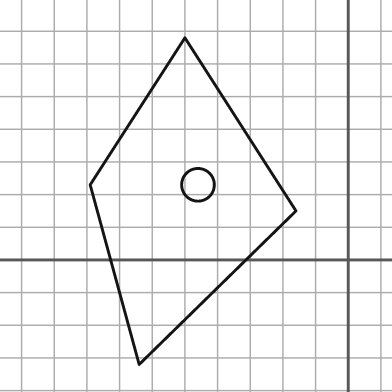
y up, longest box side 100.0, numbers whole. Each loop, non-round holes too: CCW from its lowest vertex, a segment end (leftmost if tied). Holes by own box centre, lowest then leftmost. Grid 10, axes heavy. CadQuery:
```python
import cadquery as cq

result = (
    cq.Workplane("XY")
    .moveTo(-64.0, -32.0)
    .lineTo(-16.0, 15.0)
    .lineTo(-50.0, 68.0)
    .lineTo(-79.0, 23.0)
    .close()
    .moveTo(-46.0, 23.0)
    .circle(5.0)
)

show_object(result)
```